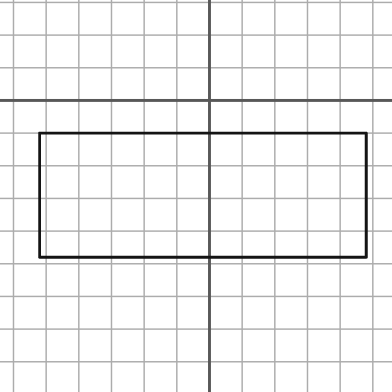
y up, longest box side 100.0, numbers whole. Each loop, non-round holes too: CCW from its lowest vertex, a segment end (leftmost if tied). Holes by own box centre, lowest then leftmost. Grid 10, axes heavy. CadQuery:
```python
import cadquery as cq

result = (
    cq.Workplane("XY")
    .moveTo(-52.0, -48.0)
    .lineTo(48.0, -48.0)
    .lineTo(48.0, -10.0)
    .lineTo(-52.0, -10.0)
    .close()
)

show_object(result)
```